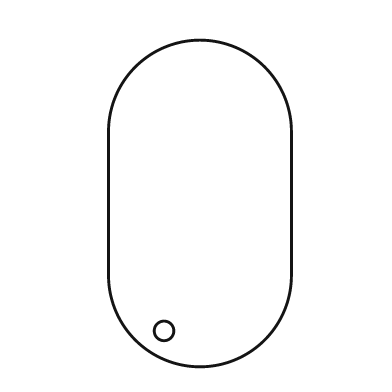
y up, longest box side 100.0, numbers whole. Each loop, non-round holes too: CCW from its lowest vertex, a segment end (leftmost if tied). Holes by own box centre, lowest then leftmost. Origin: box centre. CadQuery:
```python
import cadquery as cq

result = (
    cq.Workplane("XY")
    .moveTo(-28.0, -22.0)
    .threePointArc((0.0, -50.0), (28.0, -22.0))
    .lineTo(28.0, 22.0)
    .threePointArc((0.0, 50.0), (-28.0, 22.0))
    .close()
    .moveTo(-11.0, -39.0)
    .circle(3.0)
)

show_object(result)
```